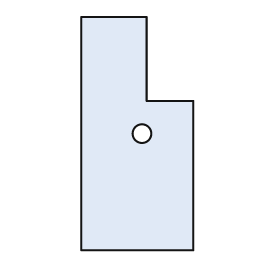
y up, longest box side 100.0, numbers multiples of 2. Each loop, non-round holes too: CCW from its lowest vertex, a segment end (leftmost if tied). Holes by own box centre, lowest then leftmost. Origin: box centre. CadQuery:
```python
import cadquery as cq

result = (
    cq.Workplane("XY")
    .moveTo(-24.0, -50.0)
    .lineTo(24.0, -50.0)
    .lineTo(24.0, 14.0)
    .lineTo(4.0, 14.0)
    .lineTo(4.0, 50.0)
    .lineTo(-24.0, 50.0)
    .close()
    .moveTo(2.0, 0.0)
    .circle(4.0)
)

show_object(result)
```